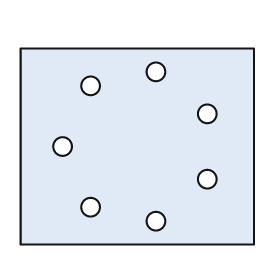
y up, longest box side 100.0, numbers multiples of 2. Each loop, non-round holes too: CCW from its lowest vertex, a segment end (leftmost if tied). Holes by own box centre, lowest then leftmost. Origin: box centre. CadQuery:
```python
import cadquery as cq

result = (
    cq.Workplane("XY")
    .moveTo(-50.0, -42.0)
    .lineTo(50.0, -42.0)
    .lineTo(50.0, 42.0)
    .lineTo(-50.0, 42.0)
    .close()
    .moveTo(8.0, -32.0)
    .circle(4.0)
    .moveTo(-20.0, -26.0)
    .circle(4.0)
    .moveTo(30.0, -14.0)
    .circle(4.0)
    .moveTo(-32.0, 0.0)
    .circle(4.0)
    .moveTo(30.0, 14.0)
    .circle(4.0)
    .moveTo(-20.0, 26.0)
    .circle(4.0)
    .moveTo(8.0, 32.0)
    .circle(4.0)
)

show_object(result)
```